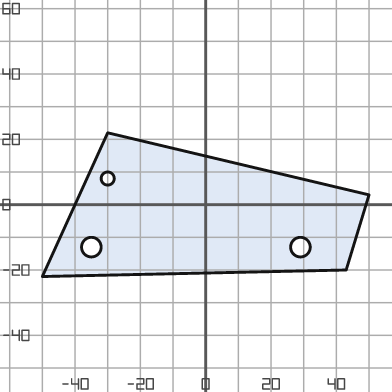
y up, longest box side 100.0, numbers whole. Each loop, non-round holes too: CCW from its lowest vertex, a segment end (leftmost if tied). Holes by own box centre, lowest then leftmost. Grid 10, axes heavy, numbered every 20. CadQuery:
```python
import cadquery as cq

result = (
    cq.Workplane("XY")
    .moveTo(-50.0, -22.0)
    .lineTo(43.0, -20.0)
    .lineTo(50.0, 3.0)
    .lineTo(-30.0, 22.0)
    .close()
    .moveTo(-35.0, -13.0)
    .circle(3.0)
    .moveTo(29.0, -13.0)
    .circle(3.0)
    .moveTo(-30.0, 8.0)
    .circle(2.0)
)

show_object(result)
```